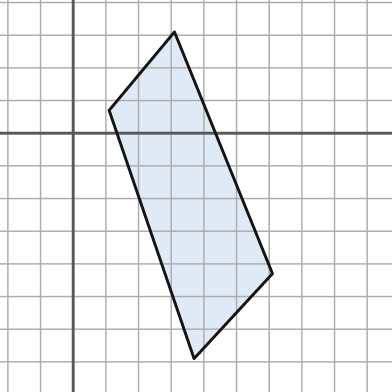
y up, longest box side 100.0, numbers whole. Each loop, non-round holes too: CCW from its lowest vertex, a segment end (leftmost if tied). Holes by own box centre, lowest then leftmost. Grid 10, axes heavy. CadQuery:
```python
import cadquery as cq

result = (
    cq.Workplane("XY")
    .moveTo(37.0, -69.0)
    .lineTo(61.0, -43.0)
    .lineTo(31.0, 31.0)
    .lineTo(11.0, 7.0)
    .close()
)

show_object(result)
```